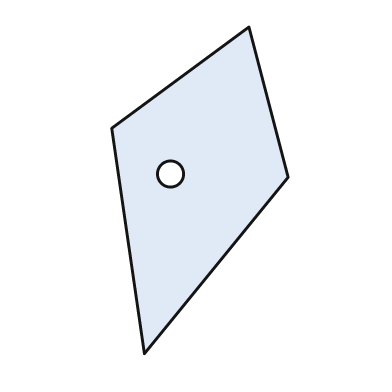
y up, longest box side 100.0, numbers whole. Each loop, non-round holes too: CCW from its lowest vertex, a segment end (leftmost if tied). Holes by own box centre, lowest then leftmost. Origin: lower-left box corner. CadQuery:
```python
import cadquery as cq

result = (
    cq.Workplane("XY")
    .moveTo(10.0, 0.0)
    .lineTo(54.0, 54.0)
    .lineTo(42.0, 100.0)
    .lineTo(0.0, 69.0)
    .close()
    .moveTo(18.0, 55.0)
    .circle(4.0)
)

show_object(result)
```